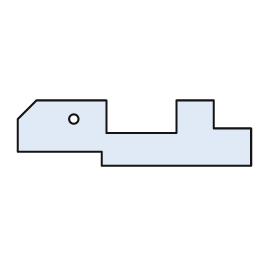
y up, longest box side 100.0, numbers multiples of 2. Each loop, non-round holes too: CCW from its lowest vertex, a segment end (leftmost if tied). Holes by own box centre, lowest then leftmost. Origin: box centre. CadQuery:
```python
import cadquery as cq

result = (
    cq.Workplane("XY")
    .moveTo(-14.0, -14.0)
    .lineTo(50.0, -14.0)
    .lineTo(50.0, 2.0)
    .lineTo(34.0, 2.0)
    .lineTo(34.0, 14.0)
    .lineTo(18.0, 14.0)
    .lineTo(18.0, 0.0)
    .lineTo(-12.0, 0.0)
    .lineTo(-12.0, 14.0)
    .lineTo(-42.0, 14.0)
    .lineTo(-50.0, 6.0)
    .lineTo(-50.0, -8.0)
    .lineTo(-14.0, -8.0)
    .close()
    .moveTo(-26.0, 6.0)
    .circle(2.0)
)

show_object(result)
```